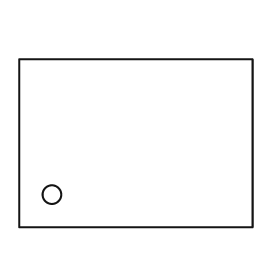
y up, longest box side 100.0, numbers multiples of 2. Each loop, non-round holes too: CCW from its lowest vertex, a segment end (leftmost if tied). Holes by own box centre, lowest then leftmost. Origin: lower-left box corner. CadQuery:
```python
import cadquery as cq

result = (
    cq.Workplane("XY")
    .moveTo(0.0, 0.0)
    .lineTo(100.0, 0.0)
    .lineTo(100.0, 72.0)
    .lineTo(0.0, 72.0)
    .close()
    .moveTo(14.0, 14.0)
    .circle(4.0)
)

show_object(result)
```